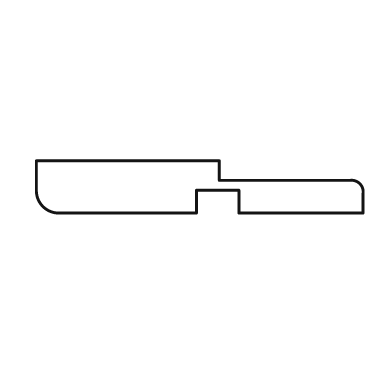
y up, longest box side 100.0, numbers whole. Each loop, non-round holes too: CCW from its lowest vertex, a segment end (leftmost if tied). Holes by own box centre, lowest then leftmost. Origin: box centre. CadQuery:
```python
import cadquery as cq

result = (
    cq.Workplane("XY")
    .moveTo(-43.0, -8.0)
    .lineTo(-1.0, -8.0)
    .lineTo(-1.0, -1.0)
    .lineTo(12.0, -1.0)
    .lineTo(12.0, -8.0)
    .lineTo(50.0, -8.0)
    .lineTo(50.0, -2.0)
    .threePointArc((49.0, 1.0), (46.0, 2.0))
    .lineTo(6.0, 2.0)
    .lineTo(6.0, 8.0)
    .lineTo(-50.0, 8.0)
    .lineTo(-50.0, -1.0)
    .threePointArc((-48.0, -6.0), (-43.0, -8.0))
    .close()
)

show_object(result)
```